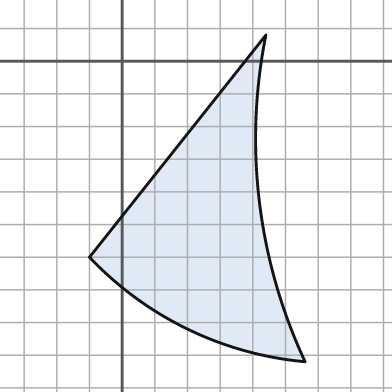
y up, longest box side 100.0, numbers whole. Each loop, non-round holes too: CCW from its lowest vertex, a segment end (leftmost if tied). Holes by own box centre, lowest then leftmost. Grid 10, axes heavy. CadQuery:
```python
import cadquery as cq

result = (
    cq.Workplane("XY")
    .moveTo(56.0, -92.0)
    .threePointArc((42.0, -43.0), (44.0, 8.0))
    .lineTo(-10.0, -60.0)
    .threePointArc((20.0, -82.0), (56.0, -92.0))
    .close()
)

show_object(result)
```